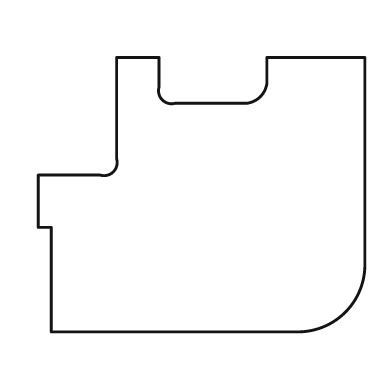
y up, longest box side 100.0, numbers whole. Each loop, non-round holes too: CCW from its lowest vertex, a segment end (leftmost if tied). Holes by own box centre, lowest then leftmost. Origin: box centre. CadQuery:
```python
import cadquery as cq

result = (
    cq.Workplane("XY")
    .moveTo(-46.0, -42.0)
    .lineTo(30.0, -42.0)
    .threePointArc((44.0, -36.0), (50.0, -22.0))
    .lineTo(50.0, 42.0)
    .lineTo(20.0, 42.0)
    .lineTo(20.0, 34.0)
    .threePointArc((18.0, 30.0), (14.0, 28.0))
    .lineTo(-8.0, 28.0)
    .threePointArc((-12.0, 29.0), (-13.0, 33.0))
    .lineTo(-13.0, 42.0)
    .lineTo(-26.0, 42.0)
    .lineTo(-26.0, 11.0)
    .threePointArc((-27.0, 7.0), (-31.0, 6.0))
    .lineTo(-50.0, 6.0)
    .lineTo(-50.0, -10.0)
    .lineTo(-46.0, -10.0)
    .close()
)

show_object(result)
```